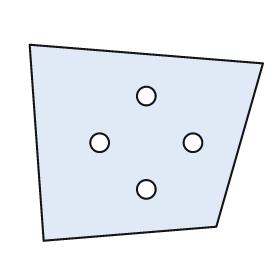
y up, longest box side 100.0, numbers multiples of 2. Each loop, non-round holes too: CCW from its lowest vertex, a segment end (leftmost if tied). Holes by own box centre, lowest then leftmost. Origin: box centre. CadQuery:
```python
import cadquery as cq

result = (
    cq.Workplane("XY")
    .moveTo(-44.0, -42.0)
    .lineTo(30.0, -36.0)
    .lineTo(50.0, 34.0)
    .lineTo(-50.0, 42.0)
    .close()
    .moveTo(0.0, -20.0)
    .circle(4.0)
    .moveTo(-20.0, 0.0)
    .circle(4.0)
    .moveTo(20.0, 0.0)
    .circle(4.0)
    .moveTo(0.0, 20.0)
    .circle(4.0)
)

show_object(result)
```